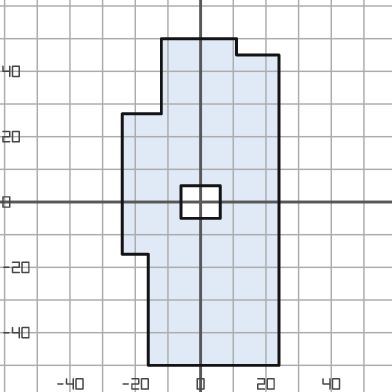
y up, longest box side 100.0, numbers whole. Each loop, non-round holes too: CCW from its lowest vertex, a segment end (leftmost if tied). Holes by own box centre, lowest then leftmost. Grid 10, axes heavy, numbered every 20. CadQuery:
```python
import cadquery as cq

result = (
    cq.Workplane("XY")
    .moveTo(-16.0, -50.0)
    .lineTo(24.0, -50.0)
    .lineTo(24.0, 45.0)
    .lineTo(11.0, 45.0)
    .lineTo(11.0, 50.0)
    .lineTo(-12.0, 50.0)
    .lineTo(-12.0, 27.0)
    .lineTo(-24.0, 27.0)
    .lineTo(-24.0, -16.0)
    .lineTo(-16.0, -16.0)
    .close()
    .moveTo(-6.0, -5.0)
    .lineTo(6.0, -5.0)
    .lineTo(6.0, 5.0)
    .lineTo(-6.0, 5.0)
    .close()
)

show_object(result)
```